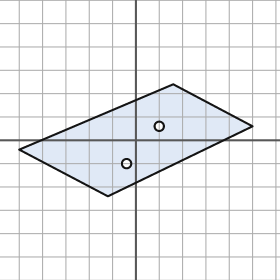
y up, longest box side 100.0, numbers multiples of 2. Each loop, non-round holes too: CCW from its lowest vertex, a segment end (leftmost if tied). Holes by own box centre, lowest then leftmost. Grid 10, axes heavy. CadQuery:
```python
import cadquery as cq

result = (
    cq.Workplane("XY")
    .moveTo(-12.0, -24.0)
    .lineTo(50.0, 6.0)
    .lineTo(16.0, 24.0)
    .lineTo(-50.0, -4.0)
    .close()
    .moveTo(-4.0, -10.0)
    .circle(2.0)
    .moveTo(10.0, 6.0)
    .circle(2.0)
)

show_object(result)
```